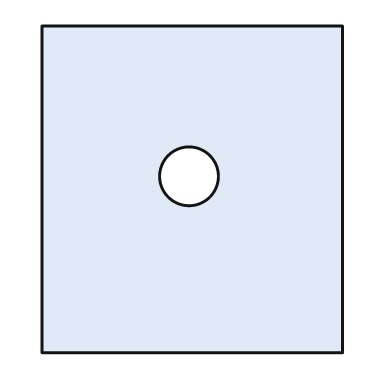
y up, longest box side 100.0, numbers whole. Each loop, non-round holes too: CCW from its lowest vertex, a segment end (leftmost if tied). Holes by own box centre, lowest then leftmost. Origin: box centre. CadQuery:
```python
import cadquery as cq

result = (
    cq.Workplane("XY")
    .moveTo(-46.0, -50.0)
    .lineTo(46.0, -50.0)
    .lineTo(46.0, 50.0)
    .lineTo(-46.0, 50.0)
    .close()
    .moveTo(-1.0, 4.0)
    .circle(9.0)
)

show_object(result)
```